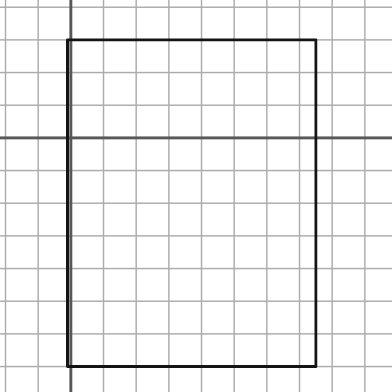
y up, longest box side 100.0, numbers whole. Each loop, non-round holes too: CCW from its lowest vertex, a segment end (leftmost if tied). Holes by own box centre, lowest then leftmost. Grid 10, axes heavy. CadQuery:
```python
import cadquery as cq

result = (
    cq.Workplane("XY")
    .moveTo(-1.0, -70.0)
    .lineTo(75.0, -70.0)
    .lineTo(75.0, 30.0)
    .lineTo(-1.0, 30.0)
    .close()
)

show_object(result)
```